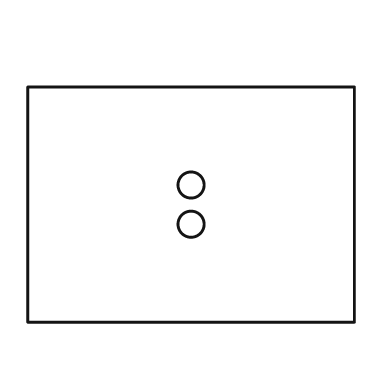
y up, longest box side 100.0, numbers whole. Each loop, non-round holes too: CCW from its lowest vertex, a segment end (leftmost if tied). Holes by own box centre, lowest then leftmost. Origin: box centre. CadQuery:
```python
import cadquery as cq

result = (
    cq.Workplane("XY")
    .moveTo(-50.0, -36.0)
    .lineTo(50.0, -36.0)
    .lineTo(50.0, 36.0)
    .lineTo(-50.0, 36.0)
    .close()
    .moveTo(0.0, -6.0)
    .circle(4.0)
    .moveTo(0.0, 6.0)
    .circle(4.0)
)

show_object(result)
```